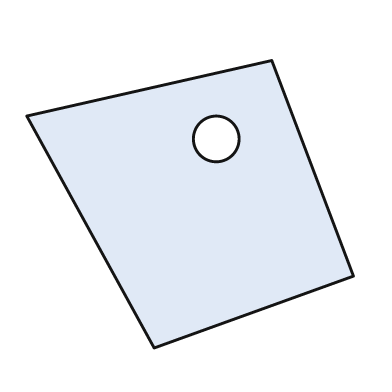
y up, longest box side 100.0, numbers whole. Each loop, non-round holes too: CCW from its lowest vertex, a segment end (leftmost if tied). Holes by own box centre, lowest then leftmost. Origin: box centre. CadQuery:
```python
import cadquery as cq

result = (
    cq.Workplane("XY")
    .moveTo(-11.0, -44.0)
    .lineTo(50.0, -22.0)
    .lineTo(25.0, 44.0)
    .lineTo(-50.0, 27.0)
    .close()
    .moveTo(8.0, 20.0)
    .circle(7.0)
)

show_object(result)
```